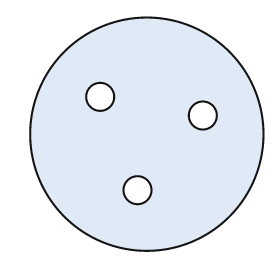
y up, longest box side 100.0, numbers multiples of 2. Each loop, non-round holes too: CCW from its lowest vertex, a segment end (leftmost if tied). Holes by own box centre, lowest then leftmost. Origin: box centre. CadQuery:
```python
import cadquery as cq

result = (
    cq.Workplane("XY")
    .moveTo(0.0, 0.0)
    .circle(50.0)
    .moveTo(-4.0, -24.0)
    .circle(6.0)
    .moveTo(24.0, 8.0)
    .circle(6.0)
    .moveTo(-20.0, 16.0)
    .circle(6.0)
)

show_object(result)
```